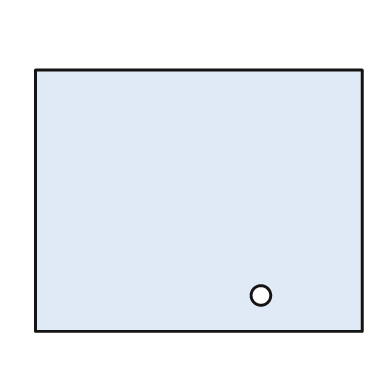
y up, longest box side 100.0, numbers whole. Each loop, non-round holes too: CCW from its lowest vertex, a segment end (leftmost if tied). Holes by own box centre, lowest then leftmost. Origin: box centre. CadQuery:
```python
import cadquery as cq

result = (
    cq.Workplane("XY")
    .moveTo(-50.0, -40.0)
    .lineTo(50.0, -40.0)
    .lineTo(50.0, 40.0)
    .lineTo(-50.0, 40.0)
    .close()
    .moveTo(19.0, -29.0)
    .circle(3.0)
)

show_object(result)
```